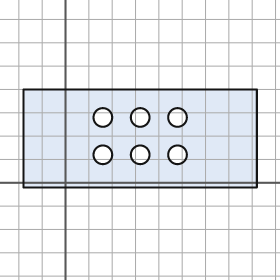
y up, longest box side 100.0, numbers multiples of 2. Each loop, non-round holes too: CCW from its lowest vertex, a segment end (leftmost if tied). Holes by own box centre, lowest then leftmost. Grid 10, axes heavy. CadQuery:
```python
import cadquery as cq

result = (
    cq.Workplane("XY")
    .moveTo(-18.0, -2.0)
    .lineTo(82.0, -2.0)
    .lineTo(82.0, 40.0)
    .lineTo(-18.0, 40.0)
    .close()
    .moveTo(16.0, 12.0)
    .circle(4.0)
    .moveTo(32.0, 12.0)
    .circle(4.0)
    .moveTo(48.0, 12.0)
    .circle(4.0)
    .moveTo(16.0, 28.0)
    .circle(4.0)
    .moveTo(32.0, 28.0)
    .circle(4.0)
    .moveTo(48.0, 28.0)
    .circle(4.0)
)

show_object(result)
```